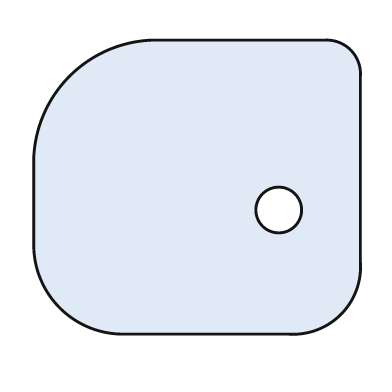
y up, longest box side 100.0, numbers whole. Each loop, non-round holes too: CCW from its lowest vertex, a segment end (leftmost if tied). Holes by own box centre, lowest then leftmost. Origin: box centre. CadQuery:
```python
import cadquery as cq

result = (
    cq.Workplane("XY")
    .moveTo(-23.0, -45.0)
    .lineTo(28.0, -45.0)
    .threePointArc((44.0, -39.0), (50.0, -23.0))
    .lineTo(50.0, 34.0)
    .threePointArc((47.0, 42.0), (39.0, 45.0))
    .lineTo(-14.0, 45.0)
    .threePointArc((-39.0, 34.0), (-50.0, 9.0))
    .lineTo(-50.0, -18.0)
    .threePointArc((-42.0, -37.0), (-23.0, -45.0))
    .close()
    .moveTo(25.0, -7.0)
    .circle(7.0)
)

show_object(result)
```